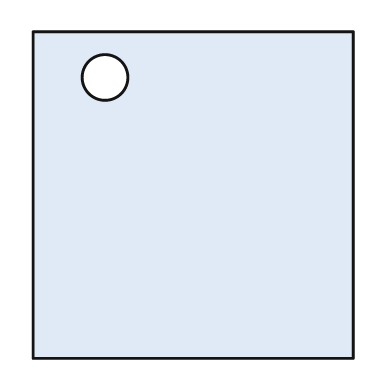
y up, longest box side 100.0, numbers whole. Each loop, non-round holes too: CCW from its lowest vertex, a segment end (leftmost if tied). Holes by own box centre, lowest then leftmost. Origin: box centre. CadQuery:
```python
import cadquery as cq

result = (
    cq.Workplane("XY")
    .moveTo(-49.0, -50.0)
    .lineTo(49.0, -50.0)
    .lineTo(49.0, 50.0)
    .lineTo(-49.0, 50.0)
    .close()
    .moveTo(-27.0, 36.0)
    .circle(7.0)
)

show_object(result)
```